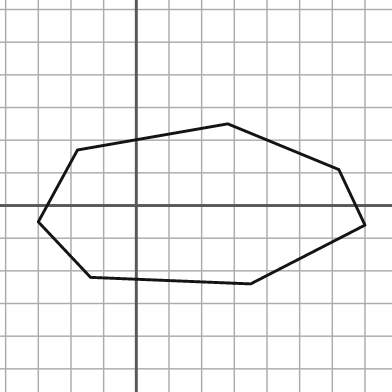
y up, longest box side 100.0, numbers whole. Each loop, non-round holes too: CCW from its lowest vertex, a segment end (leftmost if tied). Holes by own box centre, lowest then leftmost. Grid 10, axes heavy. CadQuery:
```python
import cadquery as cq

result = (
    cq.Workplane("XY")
    .moveTo(35.0, -24.0)
    .lineTo(70.0, -6.0)
    .lineTo(62.0, 11.0)
    .lineTo(28.0, 25.0)
    .lineTo(-18.0, 17.0)
    .lineTo(-30.0, -5.0)
    .lineTo(-14.0, -22.0)
    .close()
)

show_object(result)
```